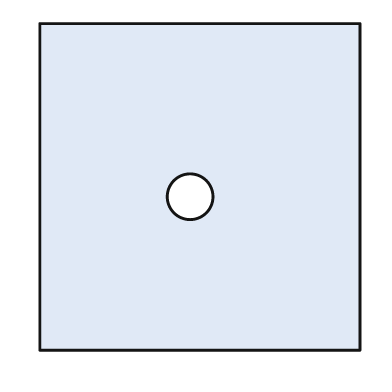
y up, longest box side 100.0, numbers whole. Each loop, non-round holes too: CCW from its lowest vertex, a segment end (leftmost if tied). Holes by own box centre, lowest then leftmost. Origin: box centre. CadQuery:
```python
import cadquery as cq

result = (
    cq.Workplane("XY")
    .moveTo(-49.0, -50.0)
    .lineTo(49.0, -50.0)
    .lineTo(49.0, 50.0)
    .lineTo(-49.0, 50.0)
    .close()
    .moveTo(-3.0, -3.0)
    .circle(7.0)
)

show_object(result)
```